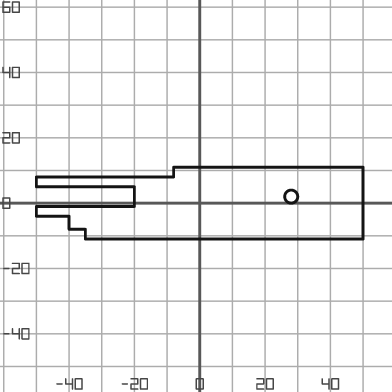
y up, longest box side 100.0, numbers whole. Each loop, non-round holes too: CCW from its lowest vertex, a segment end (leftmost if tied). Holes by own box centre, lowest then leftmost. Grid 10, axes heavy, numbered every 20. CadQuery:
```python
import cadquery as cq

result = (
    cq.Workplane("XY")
    .moveTo(-35.0, -11.0)
    .lineTo(50.0, -11.0)
    .lineTo(50.0, 11.0)
    .lineTo(-8.0, 11.0)
    .lineTo(-8.0, 8.0)
    .lineTo(-50.0, 8.0)
    .lineTo(-50.0, 5.0)
    .lineTo(-20.0, 5.0)
    .lineTo(-20.0, -1.0)
    .lineTo(-50.0, -1.0)
    .lineTo(-50.0, -4.0)
    .lineTo(-40.0, -4.0)
    .lineTo(-40.0, -8.0)
    .lineTo(-35.0, -8.0)
    .close()
    .moveTo(28.0, 2.0)
    .circle(2.0)
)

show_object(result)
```